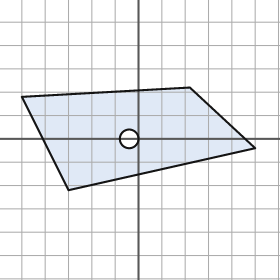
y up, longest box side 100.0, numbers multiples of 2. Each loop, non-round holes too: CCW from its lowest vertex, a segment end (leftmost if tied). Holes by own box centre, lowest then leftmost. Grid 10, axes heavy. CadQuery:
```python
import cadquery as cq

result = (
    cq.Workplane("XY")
    .moveTo(-30.0, -22.0)
    .lineTo(50.0, -4.0)
    .lineTo(22.0, 22.0)
    .lineTo(-50.0, 18.0)
    .close()
    .moveTo(-4.0, 0.0)
    .circle(4.0)
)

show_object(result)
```